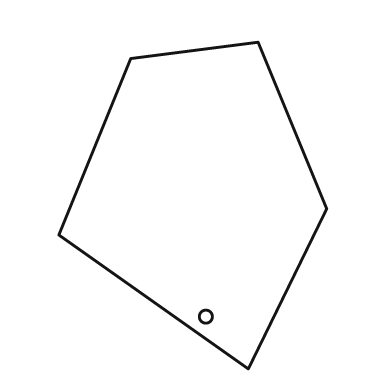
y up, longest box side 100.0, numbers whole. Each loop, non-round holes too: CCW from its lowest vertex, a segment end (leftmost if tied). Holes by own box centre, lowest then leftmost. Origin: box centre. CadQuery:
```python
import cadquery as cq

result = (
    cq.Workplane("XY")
    .moveTo(17.0, -50.0)
    .lineTo(41.0, -1.0)
    .lineTo(20.0, 50.0)
    .lineTo(-19.0, 45.0)
    .lineTo(-41.0, -9.0)
    .close()
    .moveTo(4.0, -34.0)
    .circle(2.0)
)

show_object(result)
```